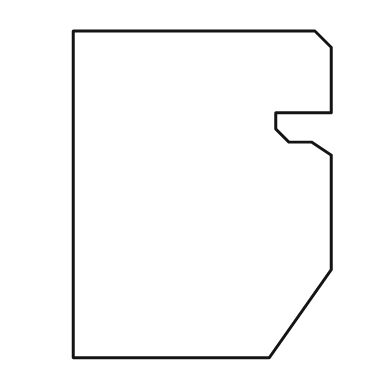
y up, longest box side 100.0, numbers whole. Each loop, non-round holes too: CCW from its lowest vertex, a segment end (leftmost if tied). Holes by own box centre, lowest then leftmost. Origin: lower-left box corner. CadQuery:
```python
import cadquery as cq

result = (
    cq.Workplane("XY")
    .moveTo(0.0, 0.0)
    .lineTo(60.0, 0.0)
    .lineTo(79.0, 27.0)
    .lineTo(79.0, 62.0)
    .lineTo(73.0, 66.0)
    .lineTo(66.0, 66.0)
    .lineTo(62.0, 70.0)
    .lineTo(62.0, 75.0)
    .lineTo(79.0, 75.0)
    .lineTo(79.0, 95.0)
    .lineTo(74.0, 100.0)
    .lineTo(0.0, 100.0)
    .close()
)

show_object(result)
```